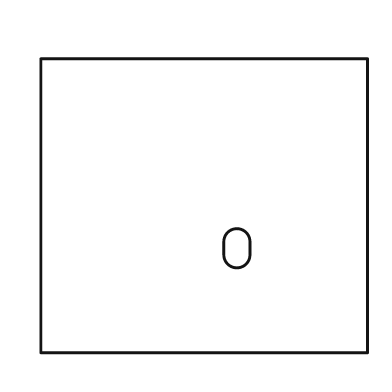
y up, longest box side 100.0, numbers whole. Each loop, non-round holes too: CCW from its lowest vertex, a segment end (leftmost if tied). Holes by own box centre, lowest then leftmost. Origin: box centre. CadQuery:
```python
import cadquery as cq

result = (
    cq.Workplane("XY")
    .moveTo(-50.0, -45.0)
    .lineTo(50.0, -45.0)
    .lineTo(50.0, 45.0)
    .lineTo(-50.0, 45.0)
    .close()
    .moveTo(6.0, -15.0)
    .threePointArc((10.0, -19.0), (14.0, -15.0))
    .lineTo(14.0, -11.0)
    .threePointArc((10.0, -7.0), (6.0, -11.0))
    .close()
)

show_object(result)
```